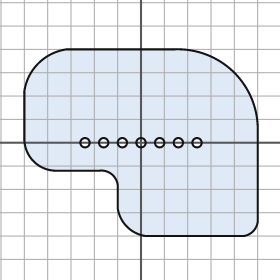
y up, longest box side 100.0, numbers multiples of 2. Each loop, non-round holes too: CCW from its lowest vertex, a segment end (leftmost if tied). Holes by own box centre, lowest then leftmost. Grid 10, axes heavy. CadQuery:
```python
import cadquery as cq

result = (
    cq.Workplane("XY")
    .moveTo(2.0, -40.0)
    .lineTo(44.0, -40.0)
    .threePointArc((48.0, -38.0), (50.0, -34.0))
    .lineTo(50.0, 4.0)
    .threePointArc((40.0, 30.0), (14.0, 40.0))
    .lineTo(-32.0, 40.0)
    .threePointArc((-44.0, 34.0), (-50.0, 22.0))
    .lineTo(-50.0, 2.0)
    .threePointArc((-46.0, -8.0), (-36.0, -12.0))
    .lineTo(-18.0, -12.0)
    .threePointArc((-12.0, -14.0), (-10.0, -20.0))
    .lineTo(-10.0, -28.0)
    .threePointArc((-6.0, -36.0), (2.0, -40.0))
    .close()
    .moveTo(-24.0, 0.0)
    .circle(2.0)
    .moveTo(-16.0, 0.0)
    .circle(2.0)
    .moveTo(-8.0, 0.0)
    .circle(2.0)
    .moveTo(0.0, 0.0)
    .circle(2.0)
    .moveTo(8.0, 0.0)
    .circle(2.0)
    .moveTo(16.0, 0.0)
    .circle(2.0)
    .moveTo(24.0, 0.0)
    .circle(2.0)
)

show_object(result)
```